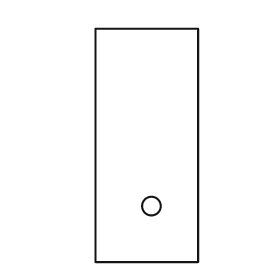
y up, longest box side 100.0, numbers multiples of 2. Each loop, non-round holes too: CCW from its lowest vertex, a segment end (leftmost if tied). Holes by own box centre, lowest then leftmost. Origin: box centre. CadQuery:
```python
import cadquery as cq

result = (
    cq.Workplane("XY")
    .moveTo(-22.0, -50.0)
    .lineTo(22.0, -50.0)
    .lineTo(22.0, 50.0)
    .lineTo(-22.0, 50.0)
    .close()
    .moveTo(2.0, -26.0)
    .circle(4.0)
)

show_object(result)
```